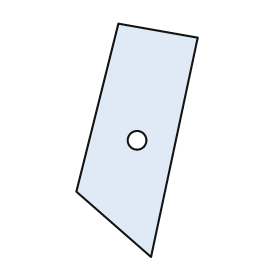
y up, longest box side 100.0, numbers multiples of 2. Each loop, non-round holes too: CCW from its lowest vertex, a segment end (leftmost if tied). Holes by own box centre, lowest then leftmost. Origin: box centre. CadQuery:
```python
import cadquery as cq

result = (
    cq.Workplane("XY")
    .moveTo(6.0, -50.0)
    .lineTo(26.0, 44.0)
    .lineTo(-8.0, 50.0)
    .lineTo(-26.0, -22.0)
    .close()
    .moveTo(0.0, 0.0)
    .circle(4.0)
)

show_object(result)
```